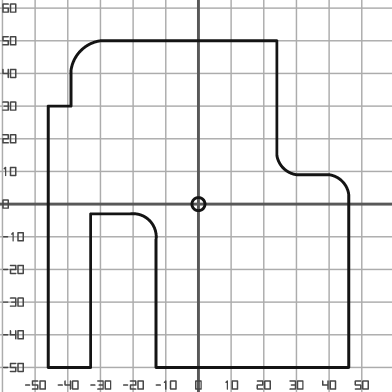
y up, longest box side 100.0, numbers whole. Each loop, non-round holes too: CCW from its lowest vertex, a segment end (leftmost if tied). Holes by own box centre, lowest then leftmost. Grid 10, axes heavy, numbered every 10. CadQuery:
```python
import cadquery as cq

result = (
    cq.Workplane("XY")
    .moveTo(-46.0, -50.0)
    .lineTo(-33.0, -50.0)
    .lineTo(-33.0, -3.0)
    .lineTo(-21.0, -3.0)
    .threePointArc((-15.0, -5.0), (-13.0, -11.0))
    .lineTo(-13.0, -50.0)
    .lineTo(46.0, -50.0)
    .lineTo(46.0, 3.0)
    .threePointArc((44.0, 7.0), (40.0, 9.0))
    .lineTo(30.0, 9.0)
    .threePointArc((26.0, 11.0), (24.0, 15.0))
    .lineTo(24.0, 50.0)
    .lineTo(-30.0, 50.0)
    .threePointArc((-36.0, 47.0), (-39.0, 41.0))
    .lineTo(-39.0, 30.0)
    .lineTo(-46.0, 30.0)
    .close()
    .moveTo(0.0, 0.0)
    .circle(2.0)
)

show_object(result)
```